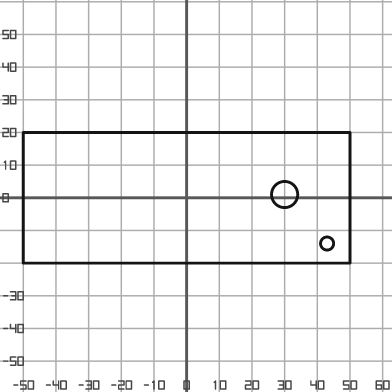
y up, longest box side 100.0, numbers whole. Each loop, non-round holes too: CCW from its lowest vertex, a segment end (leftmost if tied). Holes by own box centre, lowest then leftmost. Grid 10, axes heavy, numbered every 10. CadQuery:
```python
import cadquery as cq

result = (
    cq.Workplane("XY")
    .moveTo(-50.0, -20.0)
    .lineTo(50.0, -20.0)
    .lineTo(50.0, 20.0)
    .lineTo(-50.0, 20.0)
    .close()
    .moveTo(43.0, -14.0)
    .circle(2.0)
    .moveTo(30.0, 1.0)
    .circle(4.0)
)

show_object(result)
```